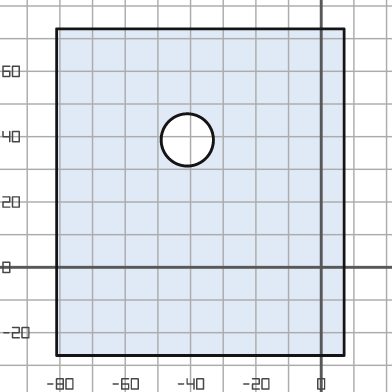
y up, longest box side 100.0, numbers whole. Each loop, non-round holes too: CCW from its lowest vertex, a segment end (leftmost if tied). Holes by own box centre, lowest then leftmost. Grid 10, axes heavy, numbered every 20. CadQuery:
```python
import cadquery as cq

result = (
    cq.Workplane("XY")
    .moveTo(-81.0, -27.0)
    .lineTo(7.0, -27.0)
    .lineTo(7.0, 73.0)
    .lineTo(-81.0, 73.0)
    .close()
    .moveTo(-41.0, 39.0)
    .circle(8.0)
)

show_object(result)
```